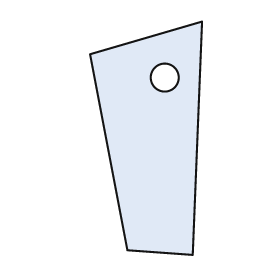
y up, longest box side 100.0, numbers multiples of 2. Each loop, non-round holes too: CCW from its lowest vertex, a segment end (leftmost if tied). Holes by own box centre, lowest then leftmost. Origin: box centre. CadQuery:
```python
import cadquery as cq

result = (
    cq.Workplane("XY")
    .moveTo(20.0, -50.0)
    .lineTo(24.0, 50.0)
    .lineTo(-24.0, 36.0)
    .lineTo(-8.0, -48.0)
    .close()
    .moveTo(8.0, 26.0)
    .circle(6.0)
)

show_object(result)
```